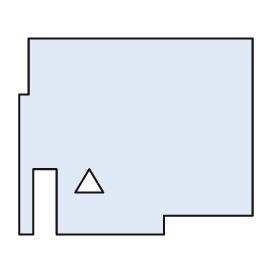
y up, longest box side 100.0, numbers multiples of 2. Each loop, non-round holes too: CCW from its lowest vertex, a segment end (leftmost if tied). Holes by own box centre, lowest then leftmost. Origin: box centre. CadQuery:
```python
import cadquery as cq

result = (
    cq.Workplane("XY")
    .moveTo(-50.0, -42.0)
    .lineTo(-44.0, -42.0)
    .lineTo(-44.0, -14.0)
    .lineTo(-34.0, -14.0)
    .lineTo(-34.0, -42.0)
    .lineTo(12.0, -42.0)
    .lineTo(12.0, -34.0)
    .lineTo(50.0, -34.0)
    .lineTo(50.0, 42.0)
    .lineTo(-46.0, 42.0)
    .lineTo(-46.0, 18.0)
    .lineTo(-50.0, 18.0)
    .close()
    .moveTo(-26.0, -24.0)
    .lineTo(-14.0, -24.0)
    .lineTo(-20.0, -14.0)
    .close()
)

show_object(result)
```